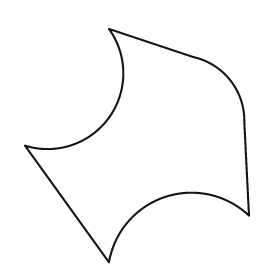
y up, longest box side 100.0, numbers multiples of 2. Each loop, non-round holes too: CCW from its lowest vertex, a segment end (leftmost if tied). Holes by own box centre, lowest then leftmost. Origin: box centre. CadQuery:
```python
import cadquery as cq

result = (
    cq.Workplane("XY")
    .moveTo(-12.0, -50.0)
    .threePointArc((12.0, -22.0), (48.0, -30.0))
    .lineTo(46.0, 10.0)
    .threePointArc((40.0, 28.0), (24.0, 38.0))
    .lineTo(-12.0, 50.0)
    .threePointArc((-12.0, 12.0), (-48.0, 0.0))
    .close()
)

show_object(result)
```